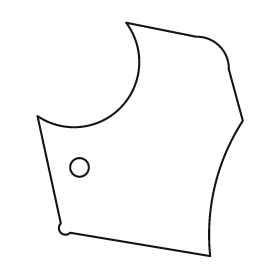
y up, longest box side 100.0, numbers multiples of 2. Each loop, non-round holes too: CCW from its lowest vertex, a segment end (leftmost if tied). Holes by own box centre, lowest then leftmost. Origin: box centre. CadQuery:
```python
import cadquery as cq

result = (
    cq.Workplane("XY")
    .moveTo(30.0, -50.0)
    .threePointArc((32.0, -20.0), (44.0, 8.0))
    .lineTo(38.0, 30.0)
    .threePointArc((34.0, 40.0), (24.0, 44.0))
    .lineTo(-6.0, 50.0)
    .threePointArc((-8.0, 14.0), (-44.0, 10.0))
    .lineTo(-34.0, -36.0)
    .threePointArc((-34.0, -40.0), (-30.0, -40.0))
    .close()
    .moveTo(-26.0, -12.0)
    .circle(4.0)
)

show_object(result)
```